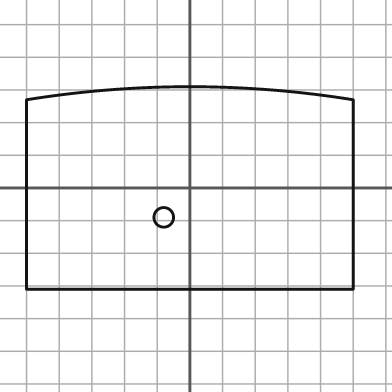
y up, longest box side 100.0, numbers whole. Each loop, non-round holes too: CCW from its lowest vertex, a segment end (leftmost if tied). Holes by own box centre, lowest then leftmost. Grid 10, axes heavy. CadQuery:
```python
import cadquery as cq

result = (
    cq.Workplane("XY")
    .moveTo(-50.0, -31.0)
    .lineTo(50.0, -31.0)
    .lineTo(50.0, 27.0)
    .threePointArc((0.0, 31.0), (-50.0, 27.0))
    .close()
    .moveTo(-8.0, -9.0)
    .circle(3.0)
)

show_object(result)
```